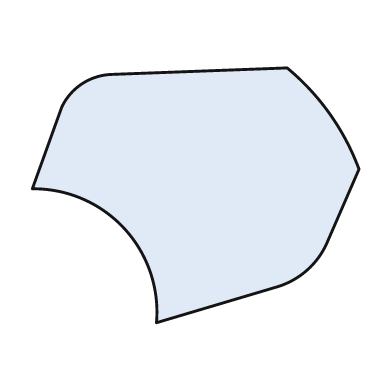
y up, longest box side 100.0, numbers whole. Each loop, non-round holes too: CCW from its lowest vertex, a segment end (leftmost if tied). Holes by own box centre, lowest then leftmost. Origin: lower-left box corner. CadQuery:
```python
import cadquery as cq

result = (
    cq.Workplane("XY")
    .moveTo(38.0, 0.0)
    .lineTo(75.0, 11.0)
    .threePointArc((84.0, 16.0), (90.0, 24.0))
    .lineTo(100.0, 47.0)
    .threePointArc((91.0, 64.0), (78.0, 78.0))
    .lineTo(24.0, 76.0)
    .threePointArc((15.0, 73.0), (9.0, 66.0))
    .lineTo(0.0, 41.0)
    .threePointArc((28.0, 29.0), (38.0, 0.0))
    .close()
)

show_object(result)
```